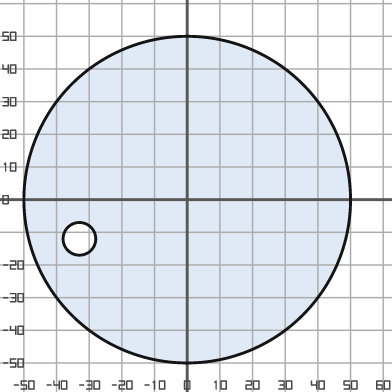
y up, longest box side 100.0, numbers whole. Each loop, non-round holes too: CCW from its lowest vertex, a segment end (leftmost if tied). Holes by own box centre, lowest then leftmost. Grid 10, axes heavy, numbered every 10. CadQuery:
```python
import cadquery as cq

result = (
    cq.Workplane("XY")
    .moveTo(0.0, 0.0)
    .circle(50.0)
    .moveTo(-33.0, -12.0)
    .circle(5.0)
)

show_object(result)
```